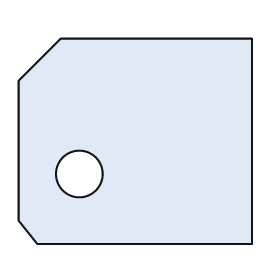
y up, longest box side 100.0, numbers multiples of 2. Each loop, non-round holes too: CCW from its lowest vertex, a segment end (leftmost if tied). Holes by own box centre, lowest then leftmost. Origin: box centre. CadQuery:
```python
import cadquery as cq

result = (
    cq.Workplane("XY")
    .moveTo(-42.0, -44.0)
    .lineTo(50.0, -44.0)
    .lineTo(50.0, 44.0)
    .lineTo(-32.0, 44.0)
    .lineTo(-50.0, 26.0)
    .lineTo(-50.0, -34.0)
    .close()
    .moveTo(-24.0, -14.0)
    .circle(10.0)
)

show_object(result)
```